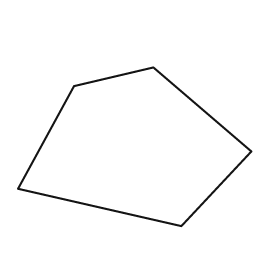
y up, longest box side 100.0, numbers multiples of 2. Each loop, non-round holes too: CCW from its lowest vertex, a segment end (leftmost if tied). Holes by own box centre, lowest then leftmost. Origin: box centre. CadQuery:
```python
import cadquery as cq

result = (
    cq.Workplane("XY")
    .moveTo(20.0, -34.0)
    .lineTo(50.0, -2.0)
    .lineTo(8.0, 34.0)
    .lineTo(-26.0, 26.0)
    .lineTo(-50.0, -18.0)
    .close()
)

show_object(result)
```